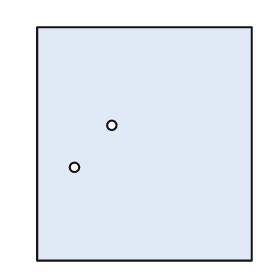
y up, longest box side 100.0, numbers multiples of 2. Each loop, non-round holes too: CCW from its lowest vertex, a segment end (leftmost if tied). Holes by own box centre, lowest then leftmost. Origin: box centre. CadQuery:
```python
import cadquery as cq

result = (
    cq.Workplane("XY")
    .moveTo(-46.0, -50.0)
    .lineTo(46.0, -50.0)
    .lineTo(46.0, 50.0)
    .lineTo(-46.0, 50.0)
    .close()
    .moveTo(-30.0, -10.0)
    .circle(2.0)
    .moveTo(-14.0, 8.0)
    .circle(2.0)
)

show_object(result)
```